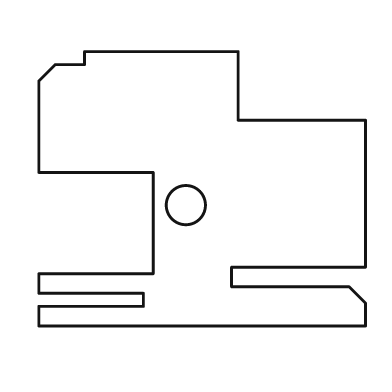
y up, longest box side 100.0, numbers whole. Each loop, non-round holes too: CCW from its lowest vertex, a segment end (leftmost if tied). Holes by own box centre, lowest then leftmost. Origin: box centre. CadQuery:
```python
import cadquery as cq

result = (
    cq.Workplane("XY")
    .moveTo(-50.0, -42.0)
    .lineTo(50.0, -42.0)
    .lineTo(50.0, -35.0)
    .lineTo(45.0, -30.0)
    .lineTo(9.0, -30.0)
    .lineTo(9.0, -24.0)
    .lineTo(50.0, -24.0)
    .lineTo(50.0, 21.0)
    .lineTo(11.0, 21.0)
    .lineTo(11.0, 42.0)
    .lineTo(-36.0, 42.0)
    .lineTo(-36.0, 38.0)
    .lineTo(-45.0, 38.0)
    .lineTo(-50.0, 33.0)
    .lineTo(-50.0, 5.0)
    .lineTo(-15.0, 5.0)
    .lineTo(-15.0, -26.0)
    .lineTo(-50.0, -26.0)
    .lineTo(-50.0, -32.0)
    .lineTo(-18.0, -32.0)
    .lineTo(-18.0, -36.0)
    .lineTo(-50.0, -36.0)
    .close()
    .moveTo(-5.0, -5.0)
    .circle(6.0)
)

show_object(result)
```